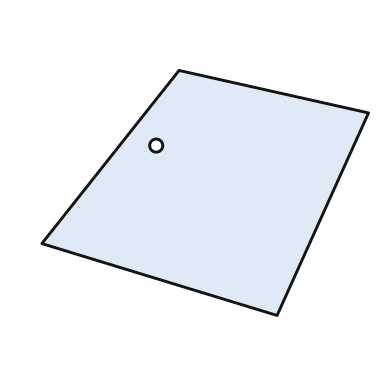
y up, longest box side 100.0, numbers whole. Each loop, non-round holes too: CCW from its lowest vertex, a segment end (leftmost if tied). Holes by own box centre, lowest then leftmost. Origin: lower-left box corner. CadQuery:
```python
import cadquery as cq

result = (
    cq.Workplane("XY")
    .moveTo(72.0, 0.0)
    .lineTo(100.0, 62.0)
    .lineTo(42.0, 75.0)
    .lineTo(0.0, 22.0)
    .close()
    .moveTo(35.0, 52.0)
    .circle(2.0)
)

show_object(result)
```